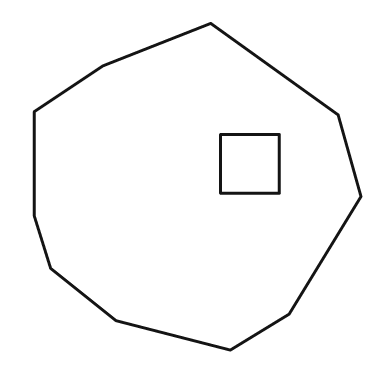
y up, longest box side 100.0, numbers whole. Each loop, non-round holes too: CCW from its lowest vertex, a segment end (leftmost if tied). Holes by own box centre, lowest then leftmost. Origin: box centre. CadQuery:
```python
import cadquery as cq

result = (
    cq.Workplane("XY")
    .moveTo(10.0, -50.0)
    .lineTo(28.0, -39.0)
    .lineTo(50.0, -3.0)
    .lineTo(43.0, 22.0)
    .lineTo(4.0, 50.0)
    .lineTo(-29.0, 37.0)
    .lineTo(-50.0, 23.0)
    .lineTo(-50.0, -9.0)
    .lineTo(-45.0, -25.0)
    .lineTo(-25.0, -41.0)
    .close()
    .moveTo(7.0, -2.0)
    .lineTo(25.0, -2.0)
    .lineTo(25.0, 16.0)
    .lineTo(7.0, 16.0)
    .close()
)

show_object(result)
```